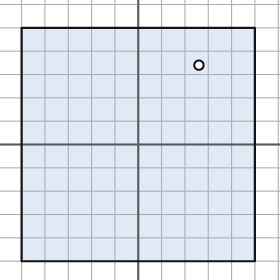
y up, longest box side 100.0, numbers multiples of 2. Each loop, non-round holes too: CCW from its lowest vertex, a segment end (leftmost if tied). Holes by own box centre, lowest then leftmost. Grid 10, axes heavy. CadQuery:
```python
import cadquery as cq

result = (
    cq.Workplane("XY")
    .moveTo(-50.0, -50.0)
    .lineTo(50.0, -50.0)
    .lineTo(50.0, 50.0)
    .lineTo(-50.0, 50.0)
    .close()
    .moveTo(26.0, 34.0)
    .circle(2.0)
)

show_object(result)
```